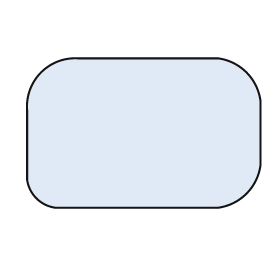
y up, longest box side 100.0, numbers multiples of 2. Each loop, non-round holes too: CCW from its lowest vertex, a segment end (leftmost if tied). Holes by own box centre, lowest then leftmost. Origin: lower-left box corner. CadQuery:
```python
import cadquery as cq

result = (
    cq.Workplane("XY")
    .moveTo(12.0, 0.0)
    .lineTo(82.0, 0.0)
    .threePointArc((94.0, 6.0), (100.0, 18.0))
    .lineTo(100.0, 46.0)
    .threePointArc((94.0, 58.0), (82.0, 64.0))
    .lineTo(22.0, 64.0)
    .threePointArc((6.0, 58.0), (0.0, 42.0))
    .lineTo(0.0, 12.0)
    .threePointArc((4.0, 4.0), (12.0, 0.0))
    .close()
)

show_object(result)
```